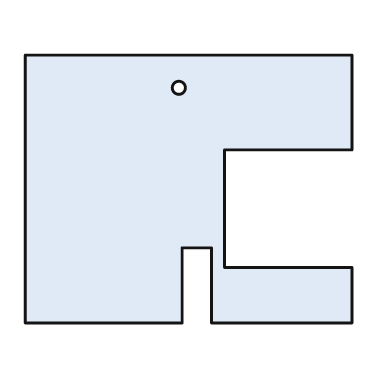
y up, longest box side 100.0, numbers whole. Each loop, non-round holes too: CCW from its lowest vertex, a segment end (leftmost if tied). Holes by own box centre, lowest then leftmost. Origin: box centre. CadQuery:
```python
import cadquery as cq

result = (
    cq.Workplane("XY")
    .moveTo(-50.0, -41.0)
    .lineTo(-2.0, -41.0)
    .lineTo(-2.0, -18.0)
    .lineTo(7.0, -18.0)
    .lineTo(7.0, -41.0)
    .lineTo(50.0, -41.0)
    .lineTo(50.0, -24.0)
    .lineTo(11.0, -24.0)
    .lineTo(11.0, 12.0)
    .lineTo(50.0, 12.0)
    .lineTo(50.0, 41.0)
    .lineTo(-50.0, 41.0)
    .close()
    .moveTo(-3.0, 31.0)
    .circle(2.0)
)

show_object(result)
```